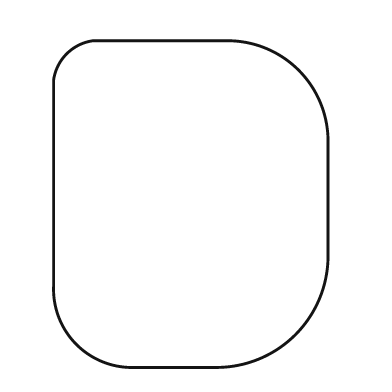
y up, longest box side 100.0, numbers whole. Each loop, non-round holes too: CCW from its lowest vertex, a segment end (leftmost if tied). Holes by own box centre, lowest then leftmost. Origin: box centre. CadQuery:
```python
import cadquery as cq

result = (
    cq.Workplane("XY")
    .moveTo(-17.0, -50.0)
    .lineTo(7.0, -50.0)
    .threePointArc((32.0, -40.0), (42.0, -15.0))
    .lineTo(42.0, 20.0)
    .threePointArc((33.0, 41.0), (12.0, 50.0))
    .lineTo(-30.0, 50.0)
    .threePointArc((-38.0, 46.0), (-42.0, 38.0))
    .lineTo(-42.0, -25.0)
    .threePointArc((-35.0, -43.0), (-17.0, -50.0))
    .close()
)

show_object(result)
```